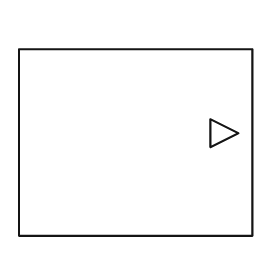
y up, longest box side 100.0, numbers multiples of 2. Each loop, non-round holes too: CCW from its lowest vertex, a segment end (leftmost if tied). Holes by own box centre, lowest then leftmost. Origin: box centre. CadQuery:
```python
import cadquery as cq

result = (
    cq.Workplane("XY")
    .moveTo(-50.0, -40.0)
    .lineTo(50.0, -40.0)
    .lineTo(50.0, 40.0)
    .lineTo(-50.0, 40.0)
    .close()
    .moveTo(32.0, -2.0)
    .lineTo(44.0, 4.0)
    .lineTo(32.0, 10.0)
    .close()
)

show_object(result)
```